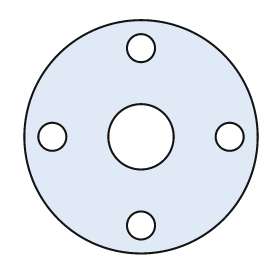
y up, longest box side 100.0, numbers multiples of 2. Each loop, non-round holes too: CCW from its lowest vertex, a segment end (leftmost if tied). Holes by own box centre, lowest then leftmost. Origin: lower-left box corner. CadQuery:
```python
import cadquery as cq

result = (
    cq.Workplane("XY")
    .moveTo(50.0, 50.0)
    .circle(50.0)
    .moveTo(50.0, 12.0)
    .circle(6.0)
    .moveTo(12.0, 50.0)
    .circle(6.0)
    .moveTo(50.0, 50.0)
    .circle(14.0)
    .moveTo(88.0, 50.0)
    .circle(6.0)
    .moveTo(50.0, 88.0)
    .circle(6.0)
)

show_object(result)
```